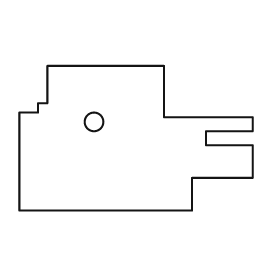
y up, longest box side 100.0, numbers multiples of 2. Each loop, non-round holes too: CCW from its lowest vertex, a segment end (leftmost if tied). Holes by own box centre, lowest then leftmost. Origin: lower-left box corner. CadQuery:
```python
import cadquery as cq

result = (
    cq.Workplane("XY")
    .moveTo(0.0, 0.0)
    .lineTo(74.0, 0.0)
    .lineTo(74.0, 14.0)
    .lineTo(100.0, 14.0)
    .lineTo(100.0, 28.0)
    .lineTo(80.0, 28.0)
    .lineTo(80.0, 34.0)
    .lineTo(100.0, 34.0)
    .lineTo(100.0, 40.0)
    .lineTo(62.0, 40.0)
    .lineTo(62.0, 62.0)
    .lineTo(12.0, 62.0)
    .lineTo(12.0, 46.0)
    .lineTo(8.0, 46.0)
    .lineTo(8.0, 42.0)
    .lineTo(0.0, 42.0)
    .close()
    .moveTo(32.0, 38.0)
    .circle(4.0)
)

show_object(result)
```